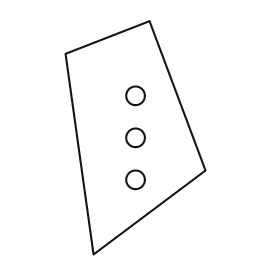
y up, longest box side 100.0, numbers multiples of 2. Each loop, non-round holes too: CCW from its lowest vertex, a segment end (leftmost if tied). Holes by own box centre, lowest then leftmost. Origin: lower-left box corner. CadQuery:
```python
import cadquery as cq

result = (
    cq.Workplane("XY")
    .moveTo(12.0, 0.0)
    .lineTo(60.0, 36.0)
    .lineTo(36.0, 100.0)
    .lineTo(0.0, 86.0)
    .close()
    .moveTo(30.0, 32.0)
    .circle(4.0)
    .moveTo(30.0, 50.0)
    .circle(4.0)
    .moveTo(30.0, 68.0)
    .circle(4.0)
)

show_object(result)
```